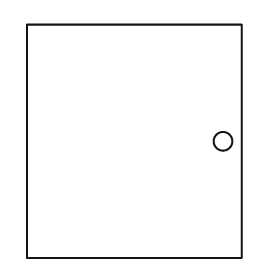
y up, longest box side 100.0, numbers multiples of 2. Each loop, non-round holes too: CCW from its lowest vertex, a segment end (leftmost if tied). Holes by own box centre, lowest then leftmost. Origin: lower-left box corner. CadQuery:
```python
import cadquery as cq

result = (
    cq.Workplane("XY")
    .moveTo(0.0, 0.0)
    .lineTo(92.0, 0.0)
    .lineTo(92.0, 100.0)
    .lineTo(0.0, 100.0)
    .close()
    .moveTo(84.0, 50.0)
    .circle(4.0)
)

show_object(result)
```